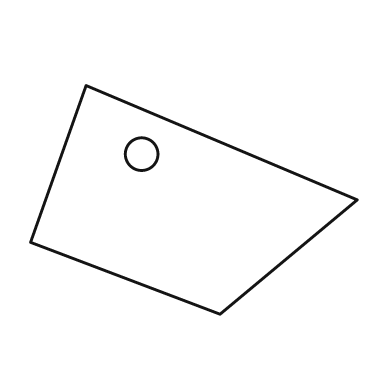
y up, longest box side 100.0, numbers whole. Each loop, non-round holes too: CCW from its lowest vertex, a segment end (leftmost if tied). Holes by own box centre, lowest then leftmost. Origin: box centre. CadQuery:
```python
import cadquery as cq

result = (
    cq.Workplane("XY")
    .moveTo(8.0, -35.0)
    .lineTo(50.0, 0.0)
    .lineTo(-33.0, 35.0)
    .lineTo(-50.0, -13.0)
    .close()
    .moveTo(-16.0, 14.0)
    .circle(5.0)
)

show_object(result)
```